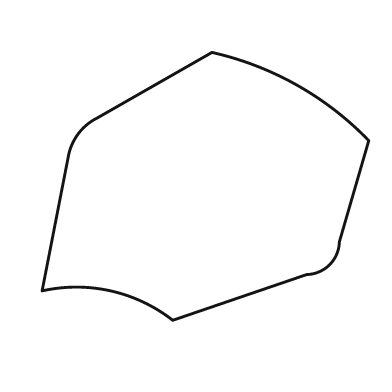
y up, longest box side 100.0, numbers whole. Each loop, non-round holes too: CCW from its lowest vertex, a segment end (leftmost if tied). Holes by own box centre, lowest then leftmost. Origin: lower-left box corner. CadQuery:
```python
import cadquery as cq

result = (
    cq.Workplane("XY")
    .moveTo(40.0, 0.0)
    .lineTo(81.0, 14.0)
    .threePointArc((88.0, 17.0), (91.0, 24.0))
    .lineTo(100.0, 55.0)
    .threePointArc((78.0, 72.0), (52.0, 82.0))
    .lineTo(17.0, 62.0)
    .threePointArc((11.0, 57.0), (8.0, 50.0))
    .lineTo(0.0, 9.0)
    .threePointArc((21.0, 9.0), (40.0, 0.0))
    .close()
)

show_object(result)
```